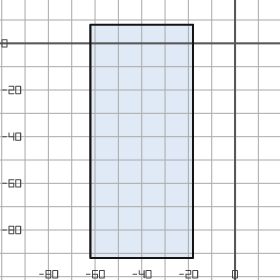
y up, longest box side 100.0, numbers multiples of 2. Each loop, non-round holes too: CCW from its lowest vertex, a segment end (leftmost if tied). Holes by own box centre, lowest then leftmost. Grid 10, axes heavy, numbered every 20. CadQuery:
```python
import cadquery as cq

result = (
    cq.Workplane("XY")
    .moveTo(-62.0, -92.0)
    .lineTo(-18.0, -92.0)
    .lineTo(-18.0, 8.0)
    .lineTo(-62.0, 8.0)
    .close()
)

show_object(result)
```